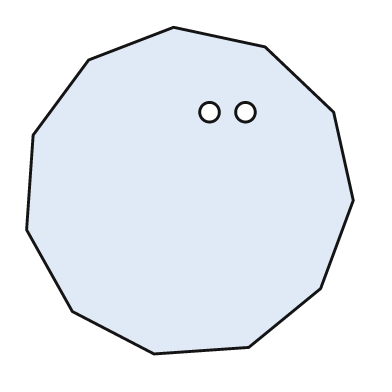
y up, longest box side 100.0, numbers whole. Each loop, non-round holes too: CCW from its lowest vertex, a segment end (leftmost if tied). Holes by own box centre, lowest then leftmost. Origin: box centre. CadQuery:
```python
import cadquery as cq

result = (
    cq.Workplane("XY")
    .moveTo(-11.0, -50.0)
    .lineTo(18.0, -48.0)
    .lineTo(40.0, -30.0)
    .lineTo(50.0, -3.0)
    .lineTo(44.0, 24.0)
    .lineTo(23.0, 44.0)
    .lineTo(-5.0, 50.0)
    .lineTo(-31.0, 40.0)
    .lineTo(-48.0, 17.0)
    .lineTo(-50.0, -12.0)
    .lineTo(-36.0, -37.0)
    .close()
    .moveTo(6.0, 24.0)
    .circle(3.0)
    .moveTo(17.0, 24.0)
    .circle(3.0)
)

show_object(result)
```